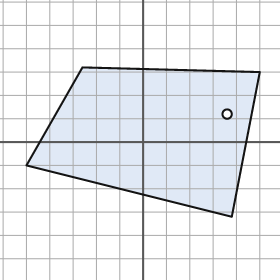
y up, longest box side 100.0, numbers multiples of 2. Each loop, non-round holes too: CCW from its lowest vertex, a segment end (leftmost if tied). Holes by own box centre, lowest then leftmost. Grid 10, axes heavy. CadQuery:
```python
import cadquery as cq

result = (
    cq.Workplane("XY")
    .moveTo(38.0, -32.0)
    .lineTo(50.0, 30.0)
    .lineTo(-26.0, 32.0)
    .lineTo(-50.0, -10.0)
    .close()
    .moveTo(36.0, 12.0)
    .circle(2.0)
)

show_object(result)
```